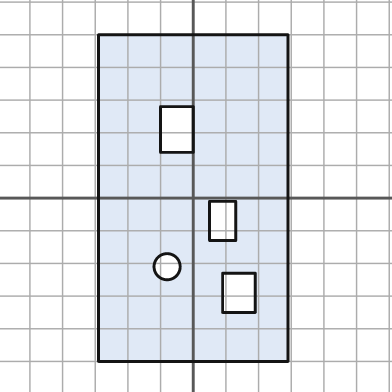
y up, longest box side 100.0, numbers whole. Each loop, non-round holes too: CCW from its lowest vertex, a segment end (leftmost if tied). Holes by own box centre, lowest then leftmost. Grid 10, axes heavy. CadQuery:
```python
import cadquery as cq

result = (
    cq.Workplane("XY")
    .moveTo(-29.0, -50.0)
    .lineTo(29.0, -50.0)
    .lineTo(29.0, 50.0)
    .lineTo(-29.0, 50.0)
    .close()
    .moveTo(9.0, -35.0)
    .lineTo(19.0, -35.0)
    .lineTo(19.0, -23.0)
    .lineTo(9.0, -23.0)
    .close()
    .moveTo(-8.0, -21.0)
    .circle(4.0)
    .moveTo(5.0, -13.0)
    .lineTo(13.0, -13.0)
    .lineTo(13.0, -1.0)
    .lineTo(5.0, -1.0)
    .close()
    .moveTo(-10.0, 14.0)
    .lineTo(0.0, 14.0)
    .lineTo(0.0, 28.0)
    .lineTo(-10.0, 28.0)
    .close()
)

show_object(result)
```